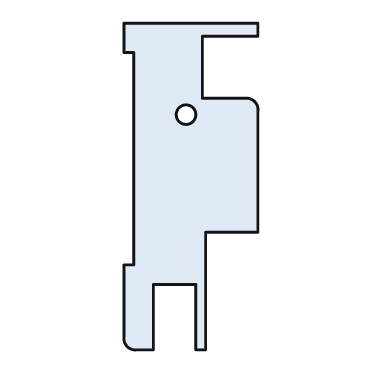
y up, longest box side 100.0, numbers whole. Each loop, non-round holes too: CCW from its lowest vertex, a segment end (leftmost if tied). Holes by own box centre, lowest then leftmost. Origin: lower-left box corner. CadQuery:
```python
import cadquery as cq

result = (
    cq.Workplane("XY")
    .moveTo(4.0, 0.0)
    .lineTo(9.0, 0.0)
    .lineTo(9.0, 20.0)
    .lineTo(22.0, 20.0)
    .lineTo(22.0, 0.0)
    .lineTo(25.0, 0.0)
    .lineTo(25.0, 36.0)
    .lineTo(41.0, 36.0)
    .lineTo(41.0, 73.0)
    .threePointArc((40.0, 76.0), (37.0, 77.0))
    .lineTo(24.0, 77.0)
    .lineTo(24.0, 96.0)
    .lineTo(41.0, 96.0)
    .lineTo(41.0, 100.0)
    .lineTo(0.0, 100.0)
    .lineTo(0.0, 91.0)
    .lineTo(3.0, 91.0)
    .lineTo(3.0, 26.0)
    .lineTo(0.0, 26.0)
    .lineTo(0.0, 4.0)
    .threePointArc((1.0, 1.0), (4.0, 0.0))
    .close()
    .moveTo(19.0, 72.0)
    .circle(3.0)
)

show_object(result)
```